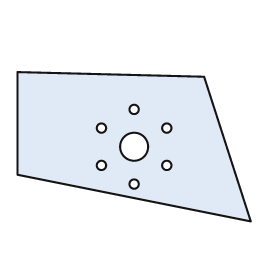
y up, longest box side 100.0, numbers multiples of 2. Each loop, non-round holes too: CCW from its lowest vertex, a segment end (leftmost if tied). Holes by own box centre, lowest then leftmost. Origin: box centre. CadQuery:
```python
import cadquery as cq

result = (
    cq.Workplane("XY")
    .moveTo(50.0, -32.0)
    .lineTo(30.0, 30.0)
    .lineTo(-50.0, 32.0)
    .lineTo(-50.0, -12.0)
    .close()
    .moveTo(0.0, -16.0)
    .circle(2.0)
    .moveTo(-14.0, -8.0)
    .circle(2.0)
    .moveTo(14.0, -8.0)
    .circle(2.0)
    .moveTo(0.0, 0.0)
    .circle(6.0)
    .moveTo(-14.0, 8.0)
    .circle(2.0)
    .moveTo(14.0, 8.0)
    .circle(2.0)
    .moveTo(0.0, 16.0)
    .circle(2.0)
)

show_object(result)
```